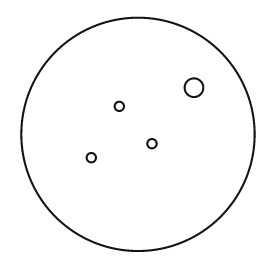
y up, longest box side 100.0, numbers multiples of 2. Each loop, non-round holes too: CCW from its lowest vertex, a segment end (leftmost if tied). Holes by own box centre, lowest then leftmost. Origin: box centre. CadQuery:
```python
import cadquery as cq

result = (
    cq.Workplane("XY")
    .moveTo(0.0, 0.0)
    .circle(50.0)
    .moveTo(-20.0, -10.0)
    .circle(2.0)
    .moveTo(6.0, -4.0)
    .circle(2.0)
    .moveTo(-8.0, 12.0)
    .circle(2.0)
    .moveTo(24.0, 20.0)
    .circle(4.0)
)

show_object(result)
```